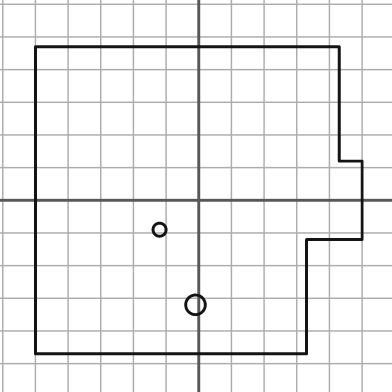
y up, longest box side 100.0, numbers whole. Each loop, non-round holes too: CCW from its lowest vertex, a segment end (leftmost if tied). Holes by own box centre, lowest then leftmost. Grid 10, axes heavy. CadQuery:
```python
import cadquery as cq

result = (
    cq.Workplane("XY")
    .moveTo(-50.0, -47.0)
    .lineTo(33.0, -47.0)
    .lineTo(33.0, -12.0)
    .lineTo(50.0, -12.0)
    .lineTo(50.0, 12.0)
    .lineTo(43.0, 12.0)
    .lineTo(43.0, 47.0)
    .lineTo(-50.0, 47.0)
    .close()
    .moveTo(-1.0, -32.0)
    .circle(3.0)
    .moveTo(-12.0, -9.0)
    .circle(2.0)
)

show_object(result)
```